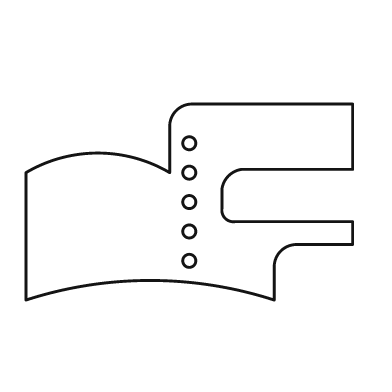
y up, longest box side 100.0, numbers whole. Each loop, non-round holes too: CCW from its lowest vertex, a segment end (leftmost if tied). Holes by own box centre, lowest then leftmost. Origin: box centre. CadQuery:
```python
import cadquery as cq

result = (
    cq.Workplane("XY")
    .moveTo(-50.0, -30.0)
    .threePointArc((-12.0, -24.0), (26.0, -30.0))
    .lineTo(26.0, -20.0)
    .threePointArc((28.0, -15.0), (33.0, -13.0))
    .lineTo(50.0, -13.0)
    .lineTo(50.0, -6.0)
    .lineTo(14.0, -6.0)
    .threePointArc((11.0, -5.0), (10.0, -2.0))
    .lineTo(10.0, 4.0)
    .threePointArc((12.0, 8.0), (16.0, 10.0))
    .lineTo(50.0, 10.0)
    .lineTo(50.0, 30.0)
    .lineTo(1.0, 30.0)
    .threePointArc((-4.0, 28.0), (-6.0, 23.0))
    .lineTo(-6.0, 9.0)
    .threePointArc((-28.0, 15.0), (-50.0, 9.0))
    .close()
    .moveTo(0.0, -18.0)
    .circle(2.0)
    .moveTo(0.0, -9.0)
    .circle(2.0)
    .moveTo(0.0, 0.0)
    .circle(2.0)
    .moveTo(0.0, 9.0)
    .circle(2.0)
    .moveTo(0.0, 18.0)
    .circle(2.0)
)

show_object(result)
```